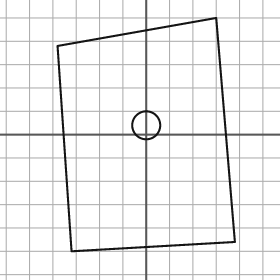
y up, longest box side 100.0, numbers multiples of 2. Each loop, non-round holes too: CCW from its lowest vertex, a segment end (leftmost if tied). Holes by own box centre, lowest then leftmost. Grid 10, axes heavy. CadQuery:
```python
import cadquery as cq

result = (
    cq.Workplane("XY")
    .moveTo(-32.0, -50.0)
    .lineTo(38.0, -46.0)
    .lineTo(30.0, 50.0)
    .lineTo(-38.0, 38.0)
    .close()
    .moveTo(0.0, 4.0)
    .circle(6.0)
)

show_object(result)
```